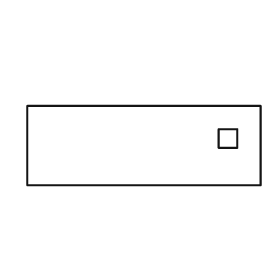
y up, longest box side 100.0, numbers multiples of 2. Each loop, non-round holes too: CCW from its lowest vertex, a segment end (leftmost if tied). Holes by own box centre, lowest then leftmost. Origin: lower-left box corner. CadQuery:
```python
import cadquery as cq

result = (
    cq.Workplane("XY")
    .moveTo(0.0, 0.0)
    .lineTo(100.0, 0.0)
    .lineTo(100.0, 34.0)
    .lineTo(0.0, 34.0)
    .close()
    .moveTo(82.0, 16.0)
    .lineTo(90.0, 16.0)
    .lineTo(90.0, 24.0)
    .lineTo(82.0, 24.0)
    .close()
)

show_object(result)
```